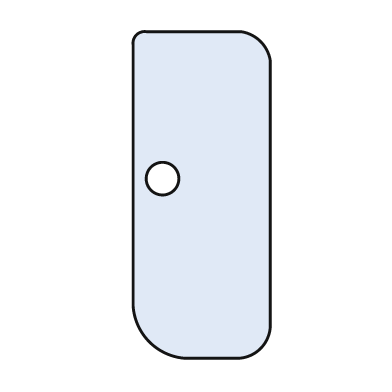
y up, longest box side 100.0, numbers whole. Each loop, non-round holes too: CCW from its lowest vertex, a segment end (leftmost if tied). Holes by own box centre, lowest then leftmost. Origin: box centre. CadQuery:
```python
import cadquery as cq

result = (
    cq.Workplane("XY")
    .moveTo(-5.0, -50.0)
    .lineTo(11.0, -50.0)
    .threePointArc((18.0, -47.0), (21.0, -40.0))
    .lineTo(21.0, 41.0)
    .threePointArc((18.0, 47.0), (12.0, 50.0))
    .lineTo(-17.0, 50.0)
    .threePointArc((-20.0, 49.0), (-21.0, 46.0))
    .lineTo(-21.0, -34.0)
    .threePointArc((-16.0, -45.0), (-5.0, -50.0))
    .close()
    .moveTo(-12.0, 5.0)
    .circle(5.0)
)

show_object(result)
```